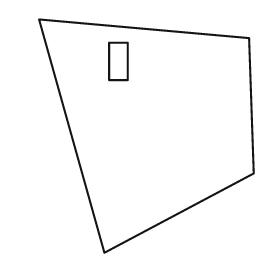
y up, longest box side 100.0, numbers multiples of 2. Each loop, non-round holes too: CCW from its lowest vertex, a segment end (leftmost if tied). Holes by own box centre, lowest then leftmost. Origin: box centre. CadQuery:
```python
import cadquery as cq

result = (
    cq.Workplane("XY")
    .moveTo(-18.0, -50.0)
    .lineTo(46.0, -16.0)
    .lineTo(44.0, 42.0)
    .lineTo(-46.0, 50.0)
    .close()
    .moveTo(-16.0, 24.0)
    .lineTo(-8.0, 24.0)
    .lineTo(-8.0, 40.0)
    .lineTo(-16.0, 40.0)
    .close()
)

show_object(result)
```